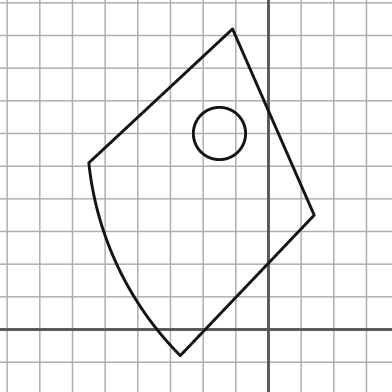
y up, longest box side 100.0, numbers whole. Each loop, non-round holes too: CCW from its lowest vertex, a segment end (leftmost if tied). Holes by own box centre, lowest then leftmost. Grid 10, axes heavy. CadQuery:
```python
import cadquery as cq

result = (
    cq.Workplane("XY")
    .moveTo(-27.0, -8.0)
    .lineTo(14.0, 35.0)
    .lineTo(-11.0, 92.0)
    .lineTo(-55.0, 51.0)
    .threePointArc((-46.0, 19.0), (-27.0, -8.0))
    .close()
    .moveTo(-15.0, 60.0)
    .circle(8.0)
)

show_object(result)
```